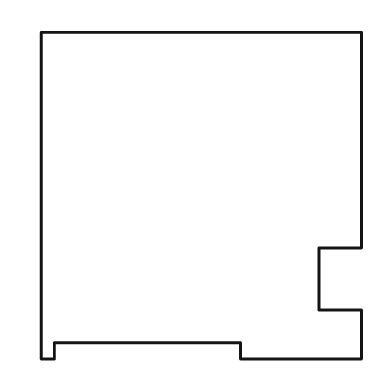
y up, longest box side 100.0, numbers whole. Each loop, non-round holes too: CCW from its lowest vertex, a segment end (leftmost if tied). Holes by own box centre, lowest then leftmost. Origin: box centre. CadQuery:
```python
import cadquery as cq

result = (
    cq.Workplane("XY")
    .moveTo(-49.0, -50.0)
    .lineTo(-45.0, -50.0)
    .lineTo(-45.0, -45.0)
    .lineTo(12.0, -45.0)
    .lineTo(12.0, -50.0)
    .lineTo(49.0, -50.0)
    .lineTo(49.0, -35.0)
    .lineTo(36.0, -35.0)
    .lineTo(36.0, -16.0)
    .lineTo(49.0, -16.0)
    .lineTo(49.0, 50.0)
    .lineTo(-49.0, 50.0)
    .close()
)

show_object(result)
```